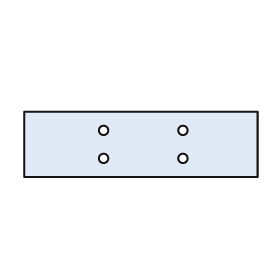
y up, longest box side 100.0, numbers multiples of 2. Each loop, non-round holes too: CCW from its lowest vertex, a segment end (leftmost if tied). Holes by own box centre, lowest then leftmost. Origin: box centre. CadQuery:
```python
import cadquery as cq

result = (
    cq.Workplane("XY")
    .moveTo(-50.0, -14.0)
    .lineTo(50.0, -14.0)
    .lineTo(50.0, 14.0)
    .lineTo(-50.0, 14.0)
    .close()
    .moveTo(-16.0, -6.0)
    .circle(2.0)
    .moveTo(18.0, -6.0)
    .circle(2.0)
    .moveTo(-16.0, 6.0)
    .circle(2.0)
    .moveTo(18.0, 6.0)
    .circle(2.0)
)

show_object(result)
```